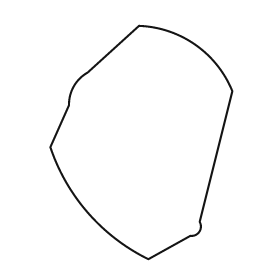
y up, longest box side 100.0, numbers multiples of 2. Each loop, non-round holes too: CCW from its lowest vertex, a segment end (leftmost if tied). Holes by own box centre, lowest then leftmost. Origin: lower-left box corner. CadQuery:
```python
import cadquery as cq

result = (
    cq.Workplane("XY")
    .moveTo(42.0, 0.0)
    .lineTo(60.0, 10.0)
    .threePointArc((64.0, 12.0), (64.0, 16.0))
    .lineTo(78.0, 72.0)
    .threePointArc((62.0, 92.0), (38.0, 100.0))
    .lineTo(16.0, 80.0)
    .threePointArc((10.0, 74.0), (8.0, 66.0))
    .lineTo(0.0, 48.0)
    .threePointArc((16.0, 20.0), (42.0, 0.0))
    .close()
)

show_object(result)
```